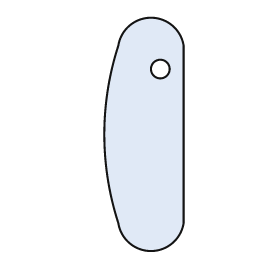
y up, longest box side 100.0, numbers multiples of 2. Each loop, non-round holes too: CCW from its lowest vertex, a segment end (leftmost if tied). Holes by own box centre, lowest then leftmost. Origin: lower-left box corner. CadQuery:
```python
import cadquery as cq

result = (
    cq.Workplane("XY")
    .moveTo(6.0, 12.0)
    .threePointArc((20.0, 0.0), (34.0, 12.0))
    .lineTo(34.0, 88.0)
    .threePointArc((20.0, 100.0), (6.0, 88.0))
    .threePointArc((0.0, 50.0), (6.0, 12.0))
    .close()
    .moveTo(24.0, 78.0)
    .circle(4.0)
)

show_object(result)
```